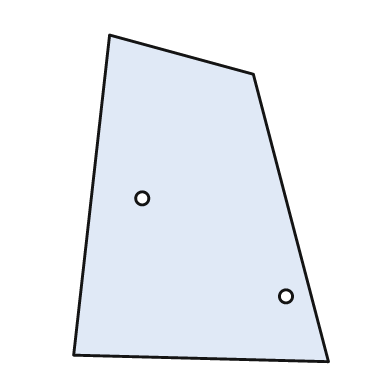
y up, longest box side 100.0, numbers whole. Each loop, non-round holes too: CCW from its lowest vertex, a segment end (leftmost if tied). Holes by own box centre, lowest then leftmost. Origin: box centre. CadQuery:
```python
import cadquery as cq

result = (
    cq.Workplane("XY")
    .moveTo(39.0, -50.0)
    .lineTo(16.0, 38.0)
    .lineTo(-28.0, 50.0)
    .lineTo(-39.0, -48.0)
    .close()
    .moveTo(26.0, -30.0)
    .circle(2.0)
    .moveTo(-18.0, 0.0)
    .circle(2.0)
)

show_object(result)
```